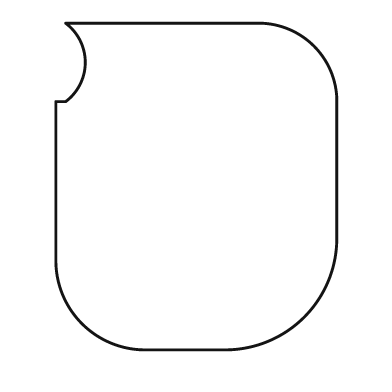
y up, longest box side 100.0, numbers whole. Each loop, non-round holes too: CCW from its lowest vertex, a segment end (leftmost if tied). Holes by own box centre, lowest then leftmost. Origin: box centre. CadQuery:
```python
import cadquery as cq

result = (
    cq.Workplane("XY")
    .moveTo(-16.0, -50.0)
    .lineTo(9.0, -50.0)
    .threePointArc((33.0, -40.0), (43.0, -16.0))
    .lineTo(43.0, 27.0)
    .threePointArc((36.0, 43.0), (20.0, 50.0))
    .lineTo(-40.0, 50.0)
    .threePointArc((-34.0, 38.0), (-40.0, 26.0))
    .lineTo(-43.0, 26.0)
    .lineTo(-43.0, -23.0)
    .threePointArc((-35.0, -42.0), (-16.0, -50.0))
    .close()
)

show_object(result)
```